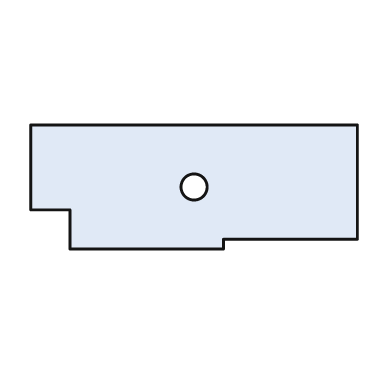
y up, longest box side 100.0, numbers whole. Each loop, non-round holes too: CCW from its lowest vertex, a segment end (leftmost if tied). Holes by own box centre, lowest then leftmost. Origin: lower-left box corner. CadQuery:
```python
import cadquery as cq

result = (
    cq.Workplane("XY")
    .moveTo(12.0, 0.0)
    .lineTo(59.0, 0.0)
    .lineTo(59.0, 3.0)
    .lineTo(100.0, 3.0)
    .lineTo(100.0, 38.0)
    .lineTo(0.0, 38.0)
    .lineTo(0.0, 12.0)
    .lineTo(12.0, 12.0)
    .close()
    .moveTo(50.0, 19.0)
    .circle(4.0)
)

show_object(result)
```